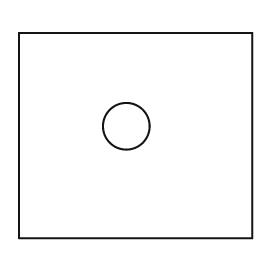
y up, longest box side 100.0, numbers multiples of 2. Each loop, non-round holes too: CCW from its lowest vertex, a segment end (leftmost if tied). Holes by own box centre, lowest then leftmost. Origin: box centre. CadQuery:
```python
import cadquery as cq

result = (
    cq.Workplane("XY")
    .moveTo(-50.0, -44.0)
    .lineTo(50.0, -44.0)
    .lineTo(50.0, 44.0)
    .lineTo(-50.0, 44.0)
    .close()
    .moveTo(-4.0, 4.0)
    .circle(10.0)
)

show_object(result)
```